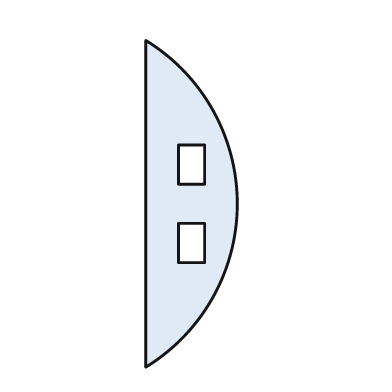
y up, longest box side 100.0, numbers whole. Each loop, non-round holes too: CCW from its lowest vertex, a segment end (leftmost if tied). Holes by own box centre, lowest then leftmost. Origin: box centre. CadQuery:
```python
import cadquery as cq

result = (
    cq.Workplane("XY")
    .moveTo(-14.0, -50.0)
    .threePointArc((14.0, 0.0), (-14.0, 50.0))
    .close()
    .moveTo(-4.0, -18.0)
    .lineTo(4.0, -18.0)
    .lineTo(4.0, -6.0)
    .lineTo(-4.0, -6.0)
    .close()
    .moveTo(-4.0, 6.0)
    .lineTo(4.0, 6.0)
    .lineTo(4.0, 18.0)
    .lineTo(-4.0, 18.0)
    .close()
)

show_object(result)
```